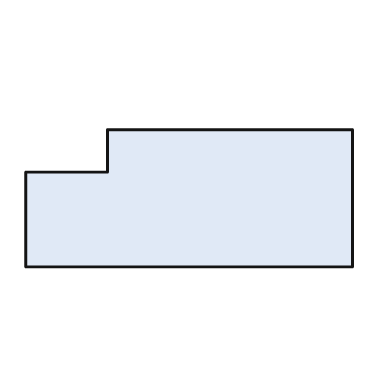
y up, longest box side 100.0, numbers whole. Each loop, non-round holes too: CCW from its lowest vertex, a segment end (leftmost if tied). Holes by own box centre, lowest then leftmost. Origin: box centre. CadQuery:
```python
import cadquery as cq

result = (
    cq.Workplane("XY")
    .moveTo(-50.0, -21.0)
    .lineTo(50.0, -21.0)
    .lineTo(50.0, 21.0)
    .lineTo(-25.0, 21.0)
    .lineTo(-25.0, 8.0)
    .lineTo(-50.0, 8.0)
    .close()
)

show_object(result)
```